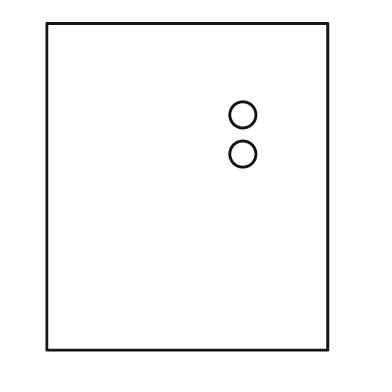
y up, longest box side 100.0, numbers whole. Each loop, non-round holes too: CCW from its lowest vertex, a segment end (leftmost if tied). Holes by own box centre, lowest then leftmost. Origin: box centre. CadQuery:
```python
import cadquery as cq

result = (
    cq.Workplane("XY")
    .moveTo(-43.0, -50.0)
    .lineTo(43.0, -50.0)
    .lineTo(43.0, 50.0)
    .lineTo(-43.0, 50.0)
    .close()
    .moveTo(17.0, 10.0)
    .circle(4.0)
    .moveTo(17.0, 22.0)
    .circle(4.0)
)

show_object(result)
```